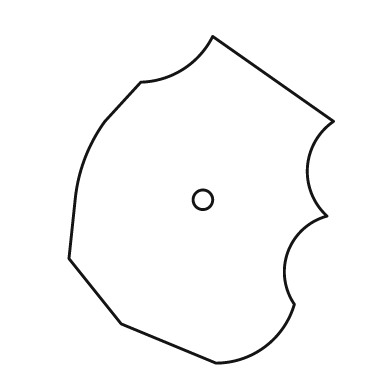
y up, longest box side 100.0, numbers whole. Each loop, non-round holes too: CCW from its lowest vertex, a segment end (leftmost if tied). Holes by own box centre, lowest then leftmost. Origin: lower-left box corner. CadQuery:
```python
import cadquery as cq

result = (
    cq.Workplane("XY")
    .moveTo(45.0, 0.0)
    .threePointArc((60.0, 5.0), (69.0, 18.0))
    .threePointArc((67.0, 34.0), (79.0, 45.0))
    .threePointArc((73.0, 60.0), (81.0, 74.0))
    .lineTo(44.0, 100.0)
    .threePointArc((35.0, 90.0), (22.0, 86.0))
    .lineTo(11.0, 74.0)
    .threePointArc((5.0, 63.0), (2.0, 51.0))
    .lineTo(0.0, 32.0)
    .lineTo(16.0, 12.0)
    .close()
    .moveTo(41.0, 50.0)
    .circle(3.0)
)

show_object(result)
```